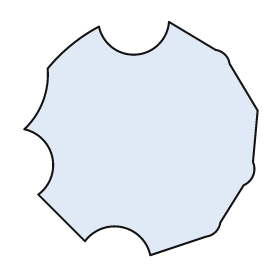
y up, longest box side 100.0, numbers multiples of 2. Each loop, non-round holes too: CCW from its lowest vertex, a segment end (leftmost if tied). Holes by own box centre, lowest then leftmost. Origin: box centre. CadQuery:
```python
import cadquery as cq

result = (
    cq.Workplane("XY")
    .moveTo(4.0, -50.0)
    .lineTo(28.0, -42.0)
    .threePointArc((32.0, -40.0), (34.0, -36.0))
    .lineTo(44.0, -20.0)
    .threePointArc((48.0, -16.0), (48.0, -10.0))
    .lineTo(50.0, 12.0)
    .lineTo(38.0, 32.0)
    .threePointArc((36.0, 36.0), (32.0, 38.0))
    .lineTo(12.0, 50.0)
    .threePointArc((-2.0, 36.0), (-18.0, 48.0))
    .threePointArc((-30.0, 40.0), (-40.0, 30.0))
    .threePointArc((-42.0, 16.0), (-50.0, 4.0))
    .threePointArc((-38.0, -8.0), (-44.0, -24.0))
    .lineTo(-24.0, -44.0)
    .threePointArc((-8.0, -38.0), (4.0, -50.0))
    .close()
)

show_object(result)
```